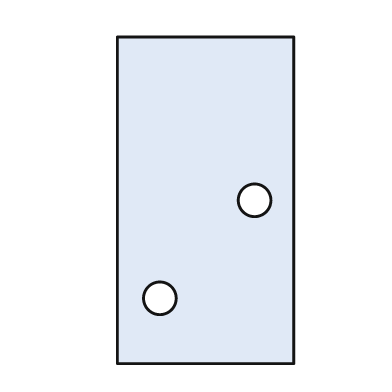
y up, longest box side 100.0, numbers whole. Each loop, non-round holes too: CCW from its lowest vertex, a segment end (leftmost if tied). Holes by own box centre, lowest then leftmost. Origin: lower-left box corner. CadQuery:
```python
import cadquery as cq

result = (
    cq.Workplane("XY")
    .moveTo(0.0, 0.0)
    .lineTo(54.0, 0.0)
    .lineTo(54.0, 100.0)
    .lineTo(0.0, 100.0)
    .close()
    .moveTo(13.0, 20.0)
    .circle(5.0)
    .moveTo(42.0, 50.0)
    .circle(5.0)
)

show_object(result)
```